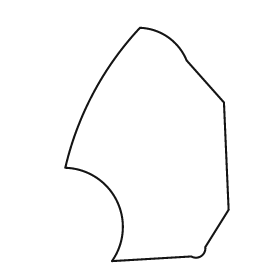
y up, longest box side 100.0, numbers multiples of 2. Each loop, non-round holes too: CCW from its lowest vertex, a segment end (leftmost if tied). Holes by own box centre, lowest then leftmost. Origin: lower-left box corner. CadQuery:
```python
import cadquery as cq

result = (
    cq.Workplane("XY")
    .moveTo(20.0, 0.0)
    .lineTo(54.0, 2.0)
    .threePointArc((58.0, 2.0), (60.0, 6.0))
    .lineTo(70.0, 22.0)
    .lineTo(68.0, 68.0)
    .lineTo(52.0, 86.0)
    .threePointArc((44.0, 96.0), (32.0, 100.0))
    .threePointArc((12.0, 72.0), (0.0, 40.0))
    .threePointArc((22.0, 26.0), (20.0, 0.0))
    .close()
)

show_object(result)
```